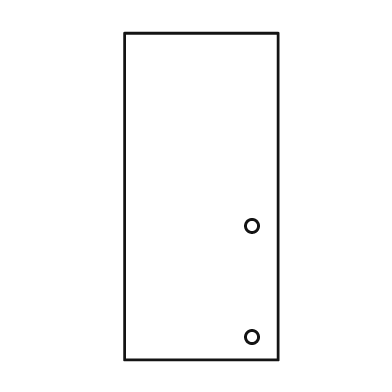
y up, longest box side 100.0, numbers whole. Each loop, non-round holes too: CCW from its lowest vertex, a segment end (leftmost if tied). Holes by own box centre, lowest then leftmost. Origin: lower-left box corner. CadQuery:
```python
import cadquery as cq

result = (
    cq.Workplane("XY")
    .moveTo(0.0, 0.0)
    .lineTo(47.0, 0.0)
    .lineTo(47.0, 100.0)
    .lineTo(0.0, 100.0)
    .close()
    .moveTo(39.0, 7.0)
    .circle(2.0)
    .moveTo(39.0, 41.0)
    .circle(2.0)
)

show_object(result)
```